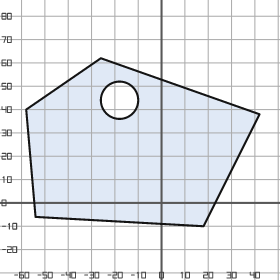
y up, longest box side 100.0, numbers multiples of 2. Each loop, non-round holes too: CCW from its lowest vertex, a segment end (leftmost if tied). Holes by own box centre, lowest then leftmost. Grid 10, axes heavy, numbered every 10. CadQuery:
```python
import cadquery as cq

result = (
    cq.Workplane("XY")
    .moveTo(18.0, -10.0)
    .lineTo(42.0, 38.0)
    .lineTo(-26.0, 62.0)
    .lineTo(-58.0, 40.0)
    .lineTo(-54.0, -6.0)
    .close()
    .moveTo(-18.0, 44.0)
    .circle(8.0)
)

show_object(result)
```